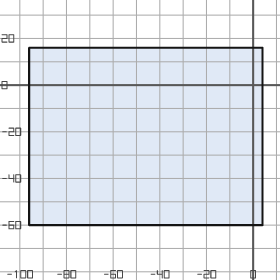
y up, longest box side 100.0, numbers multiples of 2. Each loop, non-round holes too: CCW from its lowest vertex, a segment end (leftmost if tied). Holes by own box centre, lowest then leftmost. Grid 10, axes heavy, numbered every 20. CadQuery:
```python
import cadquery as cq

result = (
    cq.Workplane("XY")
    .moveTo(-96.0, -60.0)
    .lineTo(4.0, -60.0)
    .lineTo(4.0, 16.0)
    .lineTo(-96.0, 16.0)
    .close()
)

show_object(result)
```